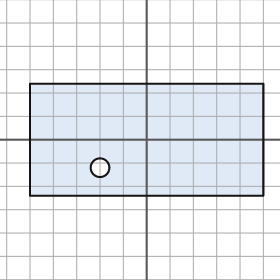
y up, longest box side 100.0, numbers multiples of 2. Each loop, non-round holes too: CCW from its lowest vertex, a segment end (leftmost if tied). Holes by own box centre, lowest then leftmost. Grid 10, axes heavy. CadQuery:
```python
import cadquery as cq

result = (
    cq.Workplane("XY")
    .moveTo(-50.0, -24.0)
    .lineTo(50.0, -24.0)
    .lineTo(50.0, 24.0)
    .lineTo(-50.0, 24.0)
    .close()
    .moveTo(-20.0, -12.0)
    .circle(4.0)
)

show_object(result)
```